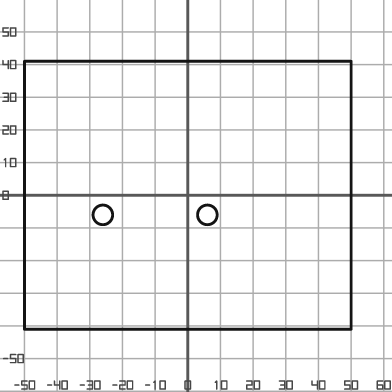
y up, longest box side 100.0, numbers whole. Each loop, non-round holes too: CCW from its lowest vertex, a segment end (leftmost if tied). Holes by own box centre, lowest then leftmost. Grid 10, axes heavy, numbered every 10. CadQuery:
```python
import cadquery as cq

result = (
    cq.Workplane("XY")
    .moveTo(-50.0, -41.0)
    .lineTo(50.0, -41.0)
    .lineTo(50.0, 41.0)
    .lineTo(-50.0, 41.0)
    .close()
    .moveTo(-26.0, -6.0)
    .circle(3.0)
    .moveTo(6.0, -6.0)
    .circle(3.0)
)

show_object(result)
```